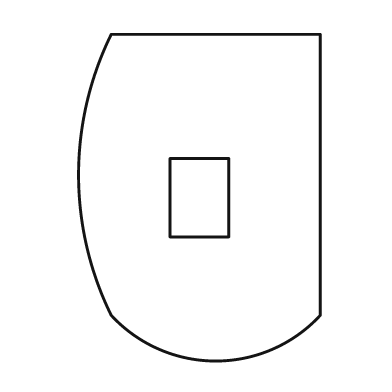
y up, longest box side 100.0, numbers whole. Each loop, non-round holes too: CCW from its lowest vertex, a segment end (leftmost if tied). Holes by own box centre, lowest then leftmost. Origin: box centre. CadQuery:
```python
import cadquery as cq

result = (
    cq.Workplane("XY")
    .moveTo(-27.0, -36.0)
    .threePointArc((5.0, -50.0), (37.0, -36.0))
    .lineTo(37.0, 50.0)
    .lineTo(-27.0, 50.0)
    .threePointArc((-37.0, 7.0), (-27.0, -36.0))
    .close()
    .moveTo(-9.0, -12.0)
    .lineTo(9.0, -12.0)
    .lineTo(9.0, 12.0)
    .lineTo(-9.0, 12.0)
    .close()
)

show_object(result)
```